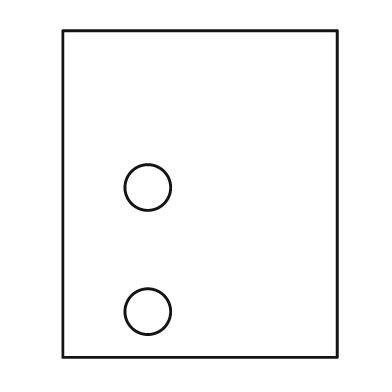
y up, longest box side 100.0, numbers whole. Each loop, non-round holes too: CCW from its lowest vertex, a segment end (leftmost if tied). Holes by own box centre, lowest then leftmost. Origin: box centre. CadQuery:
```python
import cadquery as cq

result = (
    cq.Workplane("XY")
    .moveTo(-42.0, -50.0)
    .lineTo(42.0, -50.0)
    .lineTo(42.0, 50.0)
    .lineTo(-42.0, 50.0)
    .close()
    .moveTo(-16.0, -36.0)
    .circle(7.0)
    .moveTo(-16.0, 2.0)
    .circle(7.0)
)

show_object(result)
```